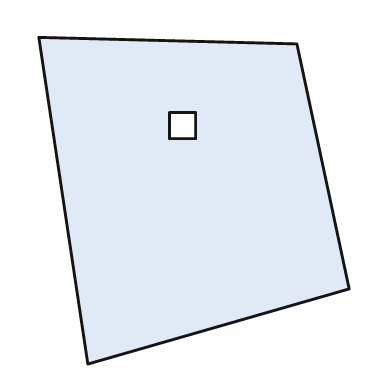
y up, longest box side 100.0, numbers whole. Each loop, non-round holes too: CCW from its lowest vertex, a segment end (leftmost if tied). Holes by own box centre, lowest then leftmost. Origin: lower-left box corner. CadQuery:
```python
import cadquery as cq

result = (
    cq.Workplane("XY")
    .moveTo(15.0, 0.0)
    .lineTo(95.0, 23.0)
    .lineTo(79.0, 98.0)
    .lineTo(0.0, 100.0)
    .close()
    .moveTo(40.0, 69.0)
    .lineTo(48.0, 69.0)
    .lineTo(48.0, 77.0)
    .lineTo(40.0, 77.0)
    .close()
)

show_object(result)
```